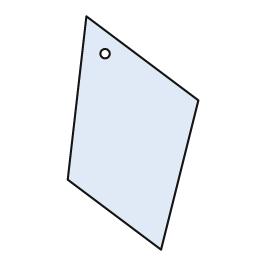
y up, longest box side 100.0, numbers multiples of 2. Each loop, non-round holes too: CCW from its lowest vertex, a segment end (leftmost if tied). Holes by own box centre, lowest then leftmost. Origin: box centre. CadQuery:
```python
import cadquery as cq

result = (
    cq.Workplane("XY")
    .moveTo(12.0, -50.0)
    .lineTo(28.0, 14.0)
    .lineTo(-20.0, 50.0)
    .lineTo(-28.0, -20.0)
    .close()
    .moveTo(-12.0, 34.0)
    .circle(2.0)
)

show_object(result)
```